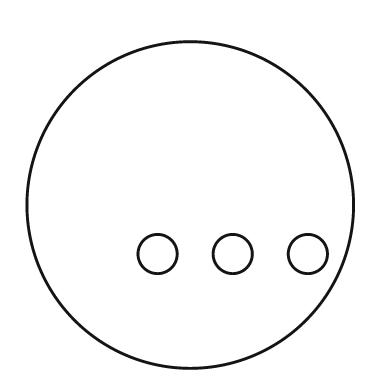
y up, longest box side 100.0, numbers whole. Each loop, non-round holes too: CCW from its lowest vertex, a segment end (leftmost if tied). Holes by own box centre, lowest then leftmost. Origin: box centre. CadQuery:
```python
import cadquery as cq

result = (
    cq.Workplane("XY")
    .moveTo(0.0, 0.0)
    .circle(50.0)
    .moveTo(-10.0, -15.0)
    .circle(6.0)
    .moveTo(13.0, -15.0)
    .circle(6.0)
    .moveTo(36.0, -15.0)
    .circle(6.0)
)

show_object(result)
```